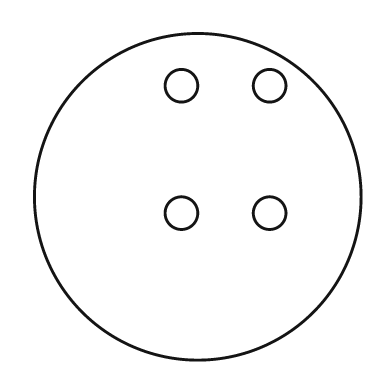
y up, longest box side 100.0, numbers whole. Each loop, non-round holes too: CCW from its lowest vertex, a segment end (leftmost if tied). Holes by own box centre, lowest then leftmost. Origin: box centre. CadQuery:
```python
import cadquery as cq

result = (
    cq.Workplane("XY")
    .moveTo(0.0, 0.0)
    .circle(50.0)
    .moveTo(-5.0, -5.0)
    .circle(5.0)
    .moveTo(22.0, -5.0)
    .circle(5.0)
    .moveTo(-5.0, 34.0)
    .circle(5.0)
    .moveTo(22.0, 34.0)
    .circle(5.0)
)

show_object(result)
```